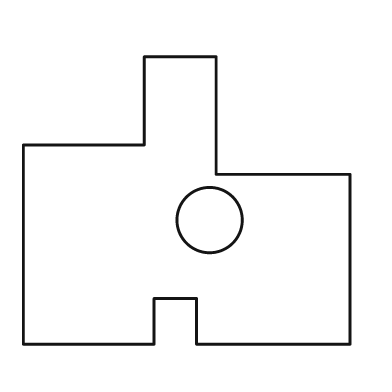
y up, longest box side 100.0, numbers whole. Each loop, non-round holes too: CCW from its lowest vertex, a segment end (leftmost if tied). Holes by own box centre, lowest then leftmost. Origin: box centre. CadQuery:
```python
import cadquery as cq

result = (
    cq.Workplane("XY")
    .moveTo(-50.0, -44.0)
    .lineTo(-10.0, -44.0)
    .lineTo(-10.0, -30.0)
    .lineTo(3.0, -30.0)
    .lineTo(3.0, -44.0)
    .lineTo(50.0, -44.0)
    .lineTo(50.0, 8.0)
    .lineTo(9.0, 8.0)
    .lineTo(9.0, 44.0)
    .lineTo(-13.0, 44.0)
    .lineTo(-13.0, 17.0)
    .lineTo(-50.0, 17.0)
    .close()
    .moveTo(7.0, -6.0)
    .circle(10.0)
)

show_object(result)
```